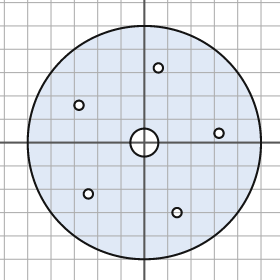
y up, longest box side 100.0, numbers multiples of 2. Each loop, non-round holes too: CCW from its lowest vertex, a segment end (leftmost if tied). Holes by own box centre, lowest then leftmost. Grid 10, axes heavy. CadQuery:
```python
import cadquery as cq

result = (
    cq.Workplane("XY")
    .moveTo(0.0, 0.0)
    .circle(50.0)
    .moveTo(14.0, -30.0)
    .circle(2.0)
    .moveTo(-24.0, -22.0)
    .circle(2.0)
    .moveTo(0.0, 0.0)
    .circle(6.0)
    .moveTo(32.0, 4.0)
    .circle(2.0)
    .moveTo(-28.0, 16.0)
    .circle(2.0)
    .moveTo(6.0, 32.0)
    .circle(2.0)
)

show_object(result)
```